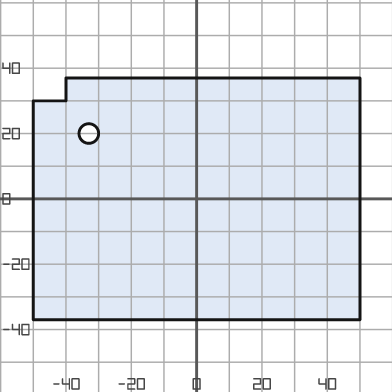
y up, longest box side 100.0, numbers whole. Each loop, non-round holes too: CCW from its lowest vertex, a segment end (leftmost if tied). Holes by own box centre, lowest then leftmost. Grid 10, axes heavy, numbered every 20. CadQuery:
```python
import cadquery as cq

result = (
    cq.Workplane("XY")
    .moveTo(-50.0, -37.0)
    .lineTo(50.0, -37.0)
    .lineTo(50.0, 37.0)
    .lineTo(-40.0, 37.0)
    .lineTo(-40.0, 30.0)
    .lineTo(-50.0, 30.0)
    .close()
    .moveTo(-33.0, 20.0)
    .circle(3.0)
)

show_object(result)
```